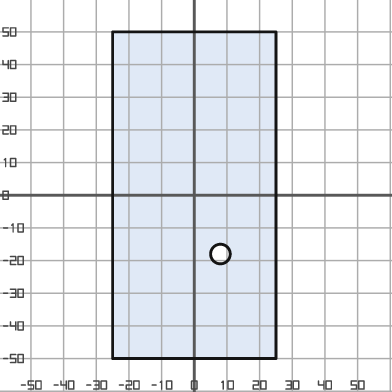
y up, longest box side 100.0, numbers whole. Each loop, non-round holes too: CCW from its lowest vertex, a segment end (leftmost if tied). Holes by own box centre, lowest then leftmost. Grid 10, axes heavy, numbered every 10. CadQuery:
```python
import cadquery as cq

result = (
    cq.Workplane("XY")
    .moveTo(-25.0, -50.0)
    .lineTo(25.0, -50.0)
    .lineTo(25.0, 50.0)
    .lineTo(-25.0, 50.0)
    .close()
    .moveTo(8.0, -18.0)
    .circle(3.0)
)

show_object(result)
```